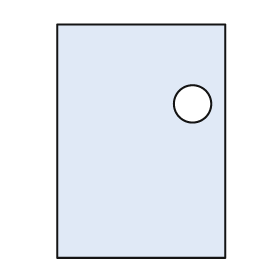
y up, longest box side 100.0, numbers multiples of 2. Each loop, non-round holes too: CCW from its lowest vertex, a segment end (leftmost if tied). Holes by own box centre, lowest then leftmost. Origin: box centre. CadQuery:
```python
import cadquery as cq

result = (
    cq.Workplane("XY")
    .moveTo(-36.0, -50.0)
    .lineTo(36.0, -50.0)
    .lineTo(36.0, 50.0)
    .lineTo(-36.0, 50.0)
    .close()
    .moveTo(22.0, 16.0)
    .circle(8.0)
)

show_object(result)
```